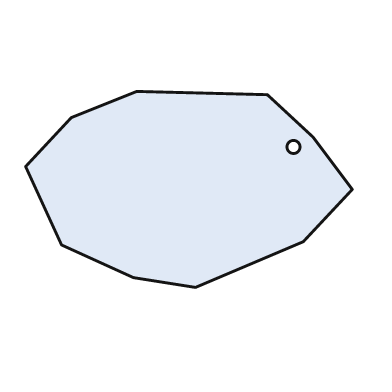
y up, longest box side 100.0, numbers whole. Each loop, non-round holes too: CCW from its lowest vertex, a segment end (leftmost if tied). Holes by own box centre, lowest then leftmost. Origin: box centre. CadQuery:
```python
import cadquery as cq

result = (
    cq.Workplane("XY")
    .moveTo(2.0, -30.0)
    .lineTo(35.0, -16.0)
    .lineTo(50.0, 0.0)
    .lineTo(38.0, 16.0)
    .lineTo(24.0, 29.0)
    .lineTo(-16.0, 30.0)
    .lineTo(-36.0, 22.0)
    .lineTo(-50.0, 7.0)
    .lineTo(-39.0, -17.0)
    .lineTo(-17.0, -27.0)
    .close()
    .moveTo(32.0, 13.0)
    .circle(2.0)
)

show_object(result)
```